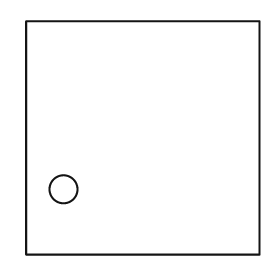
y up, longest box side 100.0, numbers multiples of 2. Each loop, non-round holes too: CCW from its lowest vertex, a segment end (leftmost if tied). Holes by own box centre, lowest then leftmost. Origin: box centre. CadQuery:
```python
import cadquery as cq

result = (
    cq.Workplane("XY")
    .moveTo(-50.0, -50.0)
    .lineTo(50.0, -50.0)
    .lineTo(50.0, 50.0)
    .lineTo(-50.0, 50.0)
    .close()
    .moveTo(-34.0, -22.0)
    .circle(6.0)
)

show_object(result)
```